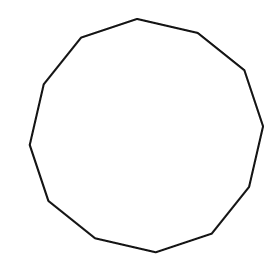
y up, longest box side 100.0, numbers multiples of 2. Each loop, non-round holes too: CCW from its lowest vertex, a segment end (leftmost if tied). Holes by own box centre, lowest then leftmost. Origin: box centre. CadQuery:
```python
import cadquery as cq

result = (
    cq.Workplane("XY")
    .moveTo(4.0, -50.0)
    .lineTo(28.0, -42.0)
    .lineTo(44.0, -22.0)
    .lineTo(50.0, 4.0)
    .lineTo(42.0, 28.0)
    .lineTo(22.0, 44.0)
    .lineTo(-4.0, 50.0)
    .lineTo(-28.0, 42.0)
    .lineTo(-44.0, 22.0)
    .lineTo(-50.0, -4.0)
    .lineTo(-42.0, -28.0)
    .lineTo(-22.0, -44.0)
    .close()
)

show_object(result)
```